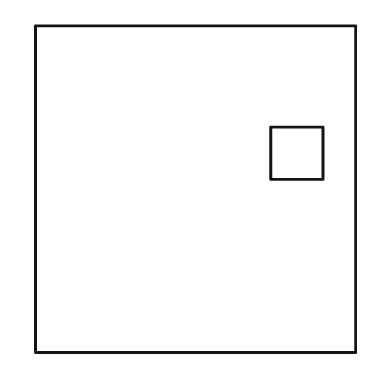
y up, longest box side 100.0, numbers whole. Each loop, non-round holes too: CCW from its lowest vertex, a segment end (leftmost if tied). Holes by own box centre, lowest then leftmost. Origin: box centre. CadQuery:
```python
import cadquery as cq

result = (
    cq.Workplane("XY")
    .moveTo(-49.0, -50.0)
    .lineTo(49.0, -50.0)
    .lineTo(49.0, 50.0)
    .lineTo(-49.0, 50.0)
    .close()
    .moveTo(23.0, 3.0)
    .lineTo(39.0, 3.0)
    .lineTo(39.0, 19.0)
    .lineTo(23.0, 19.0)
    .close()
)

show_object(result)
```